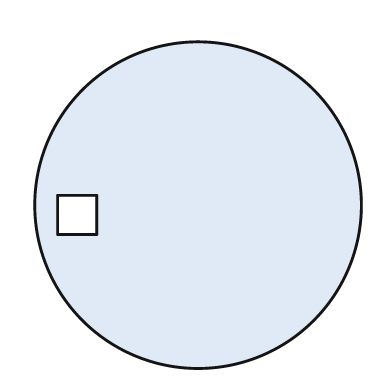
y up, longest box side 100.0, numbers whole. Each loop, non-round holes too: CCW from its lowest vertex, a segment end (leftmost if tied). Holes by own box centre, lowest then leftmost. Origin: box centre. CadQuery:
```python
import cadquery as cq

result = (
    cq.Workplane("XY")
    .moveTo(0.0, 0.0)
    .circle(50.0)
    .moveTo(-43.0, -9.0)
    .lineTo(-31.0, -9.0)
    .lineTo(-31.0, 3.0)
    .lineTo(-43.0, 3.0)
    .close()
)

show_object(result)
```